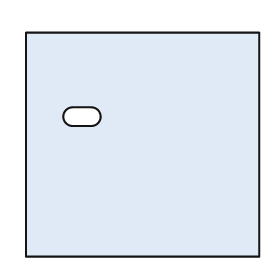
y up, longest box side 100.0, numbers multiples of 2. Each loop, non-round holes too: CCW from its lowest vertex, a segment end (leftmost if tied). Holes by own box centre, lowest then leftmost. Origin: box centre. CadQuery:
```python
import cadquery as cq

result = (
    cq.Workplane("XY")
    .moveTo(-50.0, -48.0)
    .lineTo(50.0, -48.0)
    .lineTo(50.0, 48.0)
    .lineTo(-50.0, 48.0)
    .close()
    .moveTo(-30.0, 8.0)
    .lineTo(-22.0, 8.0)
    .threePointArc((-18.0, 12.0), (-22.0, 16.0))
    .lineTo(-30.0, 16.0)
    .threePointArc((-34.0, 12.0), (-30.0, 8.0))
    .close()
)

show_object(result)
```